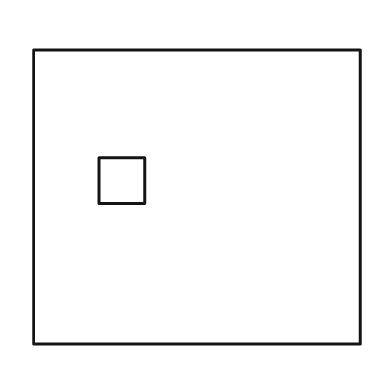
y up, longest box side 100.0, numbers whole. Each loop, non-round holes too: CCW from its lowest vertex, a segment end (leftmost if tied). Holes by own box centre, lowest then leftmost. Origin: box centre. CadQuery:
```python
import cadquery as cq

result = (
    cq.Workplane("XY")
    .moveTo(-50.0, -45.0)
    .lineTo(50.0, -45.0)
    .lineTo(50.0, 45.0)
    .lineTo(-50.0, 45.0)
    .close()
    .moveTo(-30.0, -2.0)
    .lineTo(-16.0, -2.0)
    .lineTo(-16.0, 12.0)
    .lineTo(-30.0, 12.0)
    .close()
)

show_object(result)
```